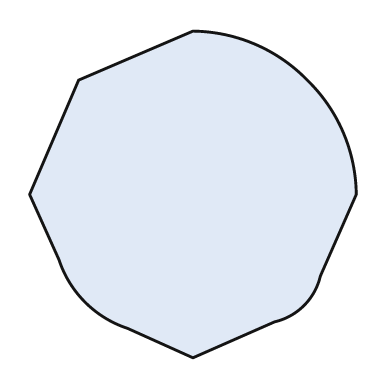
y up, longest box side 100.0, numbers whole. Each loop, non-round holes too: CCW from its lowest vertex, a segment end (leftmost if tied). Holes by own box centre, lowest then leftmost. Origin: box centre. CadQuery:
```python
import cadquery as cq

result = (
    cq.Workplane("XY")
    .moveTo(0.0, -50.0)
    .lineTo(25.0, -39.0)
    .threePointArc((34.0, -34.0), (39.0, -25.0))
    .lineTo(50.0, 0.0)
    .threePointArc((46.0, 19.0), (35.0, 35.0))
    .threePointArc((19.0, 46.0), (0.0, 50.0))
    .lineTo(-35.0, 35.0)
    .lineTo(-50.0, 0.0)
    .lineTo(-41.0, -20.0)
    .threePointArc((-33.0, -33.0), (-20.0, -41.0))
    .close()
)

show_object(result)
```